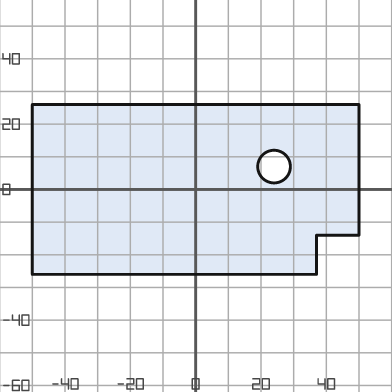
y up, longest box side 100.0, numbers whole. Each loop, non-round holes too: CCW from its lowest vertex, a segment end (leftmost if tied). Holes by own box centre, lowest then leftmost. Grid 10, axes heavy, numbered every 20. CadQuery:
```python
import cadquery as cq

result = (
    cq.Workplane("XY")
    .moveTo(-50.0, -26.0)
    .lineTo(37.0, -26.0)
    .lineTo(37.0, -14.0)
    .lineTo(50.0, -14.0)
    .lineTo(50.0, 26.0)
    .lineTo(-50.0, 26.0)
    .close()
    .moveTo(24.0, 7.0)
    .circle(5.0)
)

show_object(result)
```